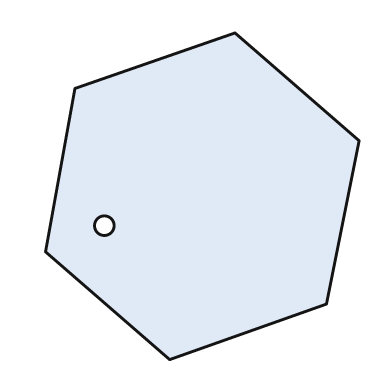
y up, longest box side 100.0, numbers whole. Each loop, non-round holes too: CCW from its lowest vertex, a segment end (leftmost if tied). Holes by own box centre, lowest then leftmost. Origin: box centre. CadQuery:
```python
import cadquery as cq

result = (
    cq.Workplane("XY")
    .moveTo(-10.0, -50.0)
    .lineTo(38.0, -33.0)
    .lineTo(48.0, 17.0)
    .lineTo(10.0, 50.0)
    .lineTo(-39.0, 33.0)
    .lineTo(-48.0, -17.0)
    .close()
    .moveTo(-30.0, -9.0)
    .circle(3.0)
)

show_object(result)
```